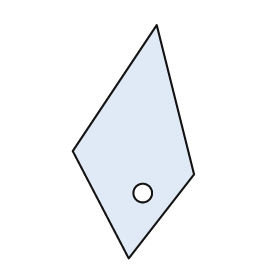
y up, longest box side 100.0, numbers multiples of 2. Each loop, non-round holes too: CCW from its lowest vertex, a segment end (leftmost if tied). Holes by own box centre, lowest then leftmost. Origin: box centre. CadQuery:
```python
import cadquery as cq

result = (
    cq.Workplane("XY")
    .moveTo(-2.0, -50.0)
    .lineTo(26.0, -14.0)
    .lineTo(10.0, 50.0)
    .lineTo(-26.0, -4.0)
    .close()
    .moveTo(4.0, -22.0)
    .circle(4.0)
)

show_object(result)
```